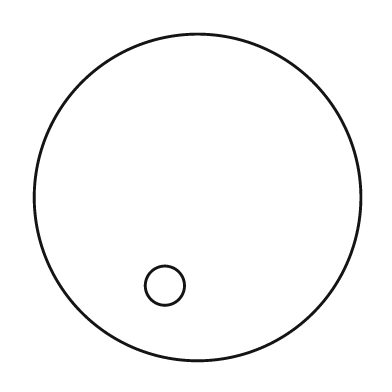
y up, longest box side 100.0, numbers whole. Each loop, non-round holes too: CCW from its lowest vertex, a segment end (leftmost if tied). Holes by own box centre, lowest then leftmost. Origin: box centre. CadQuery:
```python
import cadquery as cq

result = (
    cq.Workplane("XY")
    .moveTo(0.0, 0.0)
    .circle(50.0)
    .moveTo(-10.0, -27.0)
    .circle(6.0)
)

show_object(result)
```